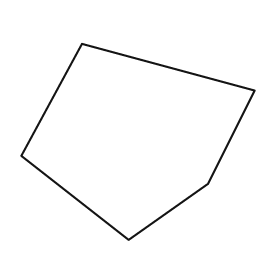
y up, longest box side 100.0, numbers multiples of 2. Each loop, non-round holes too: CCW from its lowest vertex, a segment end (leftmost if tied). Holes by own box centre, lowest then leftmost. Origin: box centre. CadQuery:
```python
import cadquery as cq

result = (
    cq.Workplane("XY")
    .moveTo(-4.0, -42.0)
    .lineTo(30.0, -18.0)
    .lineTo(50.0, 22.0)
    .lineTo(-24.0, 42.0)
    .lineTo(-50.0, -6.0)
    .close()
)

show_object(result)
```